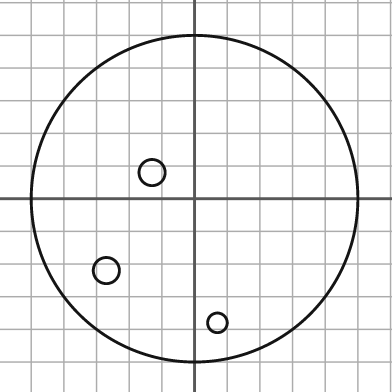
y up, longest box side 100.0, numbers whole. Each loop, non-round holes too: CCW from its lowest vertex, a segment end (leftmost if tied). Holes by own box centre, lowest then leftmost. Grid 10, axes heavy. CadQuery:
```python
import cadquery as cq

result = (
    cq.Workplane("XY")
    .moveTo(0.0, 0.0)
    .circle(50.0)
    .moveTo(7.0, -38.0)
    .circle(3.0)
    .moveTo(-27.0, -22.0)
    .circle(4.0)
    .moveTo(-13.0, 8.0)
    .circle(4.0)
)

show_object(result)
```